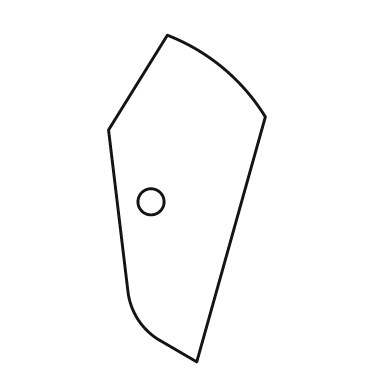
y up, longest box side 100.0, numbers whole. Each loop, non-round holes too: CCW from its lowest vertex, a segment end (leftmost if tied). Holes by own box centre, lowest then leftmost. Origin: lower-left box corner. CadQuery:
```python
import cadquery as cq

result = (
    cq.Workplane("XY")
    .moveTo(27.0, 0.0)
    .lineTo(48.0, 75.0)
    .threePointArc((35.0, 90.0), (18.0, 100.0))
    .lineTo(0.0, 71.0)
    .lineTo(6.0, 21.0)
    .threePointArc((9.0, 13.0), (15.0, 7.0))
    .close()
    .moveTo(13.0, 49.0)
    .circle(4.0)
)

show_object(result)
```